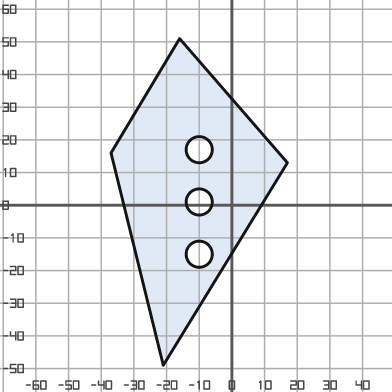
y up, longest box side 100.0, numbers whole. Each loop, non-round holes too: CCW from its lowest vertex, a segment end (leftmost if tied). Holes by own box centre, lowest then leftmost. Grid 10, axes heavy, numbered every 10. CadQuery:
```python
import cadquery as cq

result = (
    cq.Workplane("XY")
    .moveTo(-21.0, -49.0)
    .lineTo(17.0, 13.0)
    .lineTo(-16.0, 51.0)
    .lineTo(-37.0, 16.0)
    .close()
    .moveTo(-10.0, -15.0)
    .circle(4.0)
    .moveTo(-10.0, 1.0)
    .circle(4.0)
    .moveTo(-10.0, 17.0)
    .circle(4.0)
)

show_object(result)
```